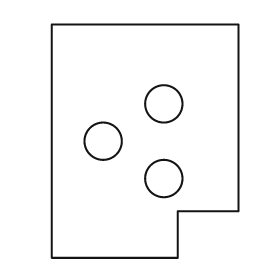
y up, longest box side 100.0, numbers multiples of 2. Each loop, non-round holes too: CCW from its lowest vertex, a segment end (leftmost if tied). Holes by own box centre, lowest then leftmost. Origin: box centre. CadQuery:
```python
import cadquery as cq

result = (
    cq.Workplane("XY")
    .moveTo(-40.0, -50.0)
    .lineTo(14.0, -50.0)
    .lineTo(14.0, -30.0)
    .lineTo(40.0, -30.0)
    .lineTo(40.0, 50.0)
    .lineTo(-40.0, 50.0)
    .close()
    .moveTo(8.0, -16.0)
    .circle(8.0)
    .moveTo(-18.0, 0.0)
    .circle(8.0)
    .moveTo(8.0, 16.0)
    .circle(8.0)
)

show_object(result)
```